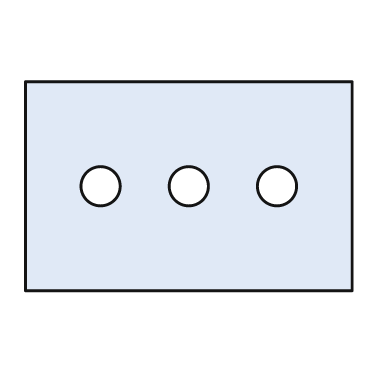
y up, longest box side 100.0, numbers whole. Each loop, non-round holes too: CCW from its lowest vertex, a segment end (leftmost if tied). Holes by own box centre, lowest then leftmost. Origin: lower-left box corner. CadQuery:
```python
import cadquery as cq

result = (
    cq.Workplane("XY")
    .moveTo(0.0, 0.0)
    .lineTo(100.0, 0.0)
    .lineTo(100.0, 64.0)
    .lineTo(0.0, 64.0)
    .close()
    .moveTo(23.0, 32.0)
    .circle(6.0)
    .moveTo(50.0, 32.0)
    .circle(6.0)
    .moveTo(77.0, 32.0)
    .circle(6.0)
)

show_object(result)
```